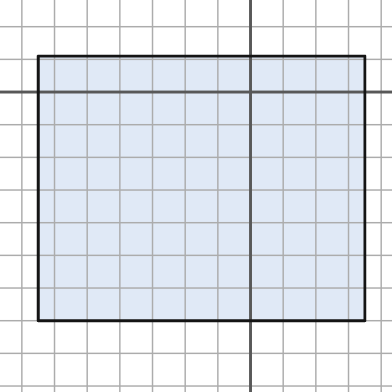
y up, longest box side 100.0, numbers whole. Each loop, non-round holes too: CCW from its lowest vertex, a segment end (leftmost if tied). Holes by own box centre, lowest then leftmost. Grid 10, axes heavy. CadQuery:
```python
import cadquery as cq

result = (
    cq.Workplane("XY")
    .moveTo(-65.0, -70.0)
    .lineTo(35.0, -70.0)
    .lineTo(35.0, 11.0)
    .lineTo(-65.0, 11.0)
    .close()
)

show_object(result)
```